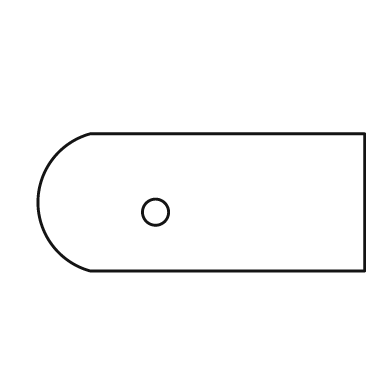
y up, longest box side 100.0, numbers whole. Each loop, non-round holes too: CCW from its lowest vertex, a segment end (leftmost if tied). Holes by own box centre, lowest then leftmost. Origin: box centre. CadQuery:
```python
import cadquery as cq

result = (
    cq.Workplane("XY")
    .moveTo(-34.0, -21.0)
    .lineTo(50.0, -21.0)
    .lineTo(50.0, 21.0)
    .lineTo(-34.0, 21.0)
    .threePointArc((-50.0, 0.0), (-34.0, -21.0))
    .close()
    .moveTo(-14.0, -3.0)
    .circle(4.0)
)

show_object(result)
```